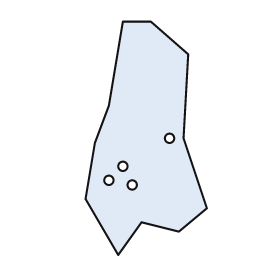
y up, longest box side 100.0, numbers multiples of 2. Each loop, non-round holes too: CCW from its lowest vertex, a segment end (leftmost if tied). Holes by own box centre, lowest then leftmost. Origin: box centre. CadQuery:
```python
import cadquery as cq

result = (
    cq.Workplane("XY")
    .moveTo(-12.0, -50.0)
    .lineTo(-2.0, -36.0)
    .lineTo(14.0, -40.0)
    .lineTo(26.0, -30.0)
    .lineTo(16.0, 0.0)
    .lineTo(18.0, 36.0)
    .lineTo(2.0, 50.0)
    .lineTo(-10.0, 50.0)
    .lineTo(-16.0, 14.0)
    .lineTo(-22.0, -2.0)
    .lineTo(-26.0, -26.0)
    .close()
    .moveTo(-6.0, -20.0)
    .circle(2.0)
    .moveTo(-16.0, -18.0)
    .circle(2.0)
    .moveTo(-10.0, -12.0)
    .circle(2.0)
    .moveTo(10.0, 0.0)
    .circle(2.0)
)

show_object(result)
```